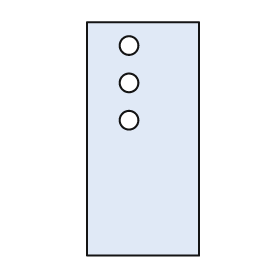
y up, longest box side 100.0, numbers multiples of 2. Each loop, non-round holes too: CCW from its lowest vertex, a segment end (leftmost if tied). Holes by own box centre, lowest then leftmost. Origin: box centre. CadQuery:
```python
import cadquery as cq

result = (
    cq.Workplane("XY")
    .moveTo(-24.0, -50.0)
    .lineTo(24.0, -50.0)
    .lineTo(24.0, 50.0)
    .lineTo(-24.0, 50.0)
    .close()
    .moveTo(-6.0, 8.0)
    .circle(4.0)
    .moveTo(-6.0, 24.0)
    .circle(4.0)
    .moveTo(-6.0, 40.0)
    .circle(4.0)
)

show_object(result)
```